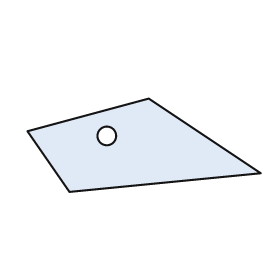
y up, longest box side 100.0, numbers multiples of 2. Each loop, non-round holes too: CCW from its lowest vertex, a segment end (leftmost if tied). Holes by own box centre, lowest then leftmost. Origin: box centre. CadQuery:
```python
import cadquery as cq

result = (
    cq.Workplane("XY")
    .moveTo(-32.0, -20.0)
    .lineTo(50.0, -12.0)
    .lineTo(2.0, 20.0)
    .lineTo(-50.0, 6.0)
    .close()
    .moveTo(-16.0, 4.0)
    .circle(4.0)
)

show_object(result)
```